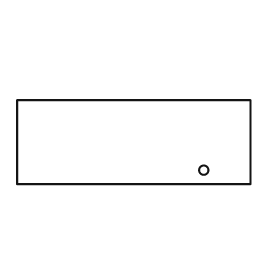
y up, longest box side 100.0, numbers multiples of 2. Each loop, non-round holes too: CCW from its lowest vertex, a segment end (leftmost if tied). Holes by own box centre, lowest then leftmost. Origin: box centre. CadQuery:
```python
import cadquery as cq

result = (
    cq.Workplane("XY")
    .moveTo(-50.0, -18.0)
    .lineTo(50.0, -18.0)
    .lineTo(50.0, 18.0)
    .lineTo(-50.0, 18.0)
    .close()
    .moveTo(30.0, -12.0)
    .circle(2.0)
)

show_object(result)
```